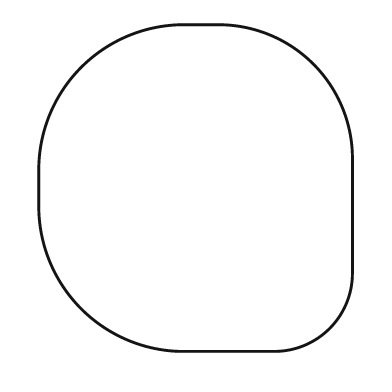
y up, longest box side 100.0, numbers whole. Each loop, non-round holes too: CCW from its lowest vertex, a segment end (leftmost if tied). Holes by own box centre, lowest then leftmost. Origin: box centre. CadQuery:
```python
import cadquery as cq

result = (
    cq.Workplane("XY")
    .moveTo(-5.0, -50.0)
    .lineTo(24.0, -50.0)
    .threePointArc((41.0, -43.0), (48.0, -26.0))
    .lineTo(48.0, 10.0)
    .threePointArc((36.0, 38.0), (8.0, 50.0))
    .lineTo(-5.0, 50.0)
    .threePointArc((-35.0, 37.0), (-48.0, 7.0))
    .lineTo(-48.0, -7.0)
    .threePointArc((-35.0, -37.0), (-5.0, -50.0))
    .close()
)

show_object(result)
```